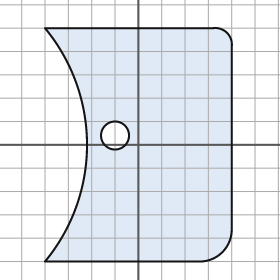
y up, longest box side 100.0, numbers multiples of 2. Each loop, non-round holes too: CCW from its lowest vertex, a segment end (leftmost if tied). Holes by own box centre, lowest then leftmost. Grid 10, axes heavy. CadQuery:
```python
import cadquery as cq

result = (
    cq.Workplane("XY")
    .moveTo(-40.0, -50.0)
    .lineTo(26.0, -50.0)
    .threePointArc((36.0, -46.0), (40.0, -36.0))
    .lineTo(40.0, 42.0)
    .threePointArc((38.0, 48.0), (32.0, 50.0))
    .lineTo(-40.0, 50.0)
    .threePointArc((-22.0, 0.0), (-40.0, -50.0))
    .close()
    .moveTo(-10.0, 4.0)
    .circle(6.0)
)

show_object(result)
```